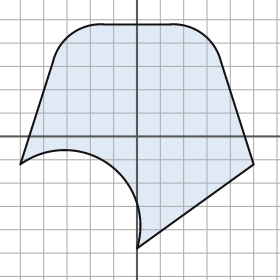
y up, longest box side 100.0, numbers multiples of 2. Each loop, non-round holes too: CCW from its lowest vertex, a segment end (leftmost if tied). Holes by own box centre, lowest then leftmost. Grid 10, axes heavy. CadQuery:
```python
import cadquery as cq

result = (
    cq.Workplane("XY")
    .moveTo(0.0, -48.0)
    .lineTo(50.0, -12.0)
    .lineTo(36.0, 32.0)
    .threePointArc((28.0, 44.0), (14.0, 48.0))
    .lineTo(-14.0, 48.0)
    .threePointArc((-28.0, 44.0), (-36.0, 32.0))
    .lineTo(-50.0, -12.0)
    .threePointArc((-12.0, -12.0), (0.0, -48.0))
    .close()
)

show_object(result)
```